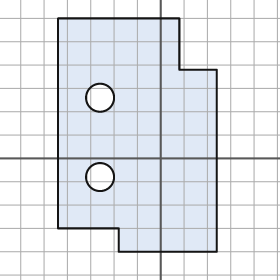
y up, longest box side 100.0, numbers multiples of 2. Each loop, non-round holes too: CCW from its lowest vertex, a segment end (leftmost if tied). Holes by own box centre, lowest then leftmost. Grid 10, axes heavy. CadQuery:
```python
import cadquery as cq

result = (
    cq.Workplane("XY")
    .moveTo(-18.0, -40.0)
    .lineTo(24.0, -40.0)
    .lineTo(24.0, 38.0)
    .lineTo(8.0, 38.0)
    .lineTo(8.0, 60.0)
    .lineTo(-44.0, 60.0)
    .lineTo(-44.0, -30.0)
    .lineTo(-18.0, -30.0)
    .close()
    .moveTo(-26.0, -8.0)
    .circle(6.0)
    .moveTo(-26.0, 26.0)
    .circle(6.0)
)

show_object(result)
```